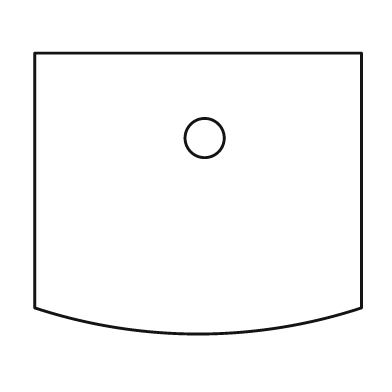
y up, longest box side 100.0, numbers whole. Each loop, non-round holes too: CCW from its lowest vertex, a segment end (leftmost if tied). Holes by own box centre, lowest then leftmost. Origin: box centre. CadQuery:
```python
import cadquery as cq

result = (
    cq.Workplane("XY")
    .moveTo(-50.0, -35.0)
    .threePointArc((0.0, -43.0), (50.0, -35.0))
    .lineTo(50.0, 43.0)
    .lineTo(-50.0, 43.0)
    .close()
    .moveTo(2.0, 17.0)
    .circle(6.0)
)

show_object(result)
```